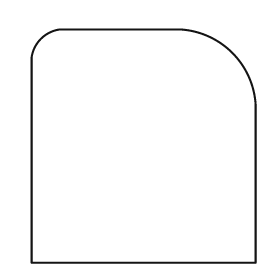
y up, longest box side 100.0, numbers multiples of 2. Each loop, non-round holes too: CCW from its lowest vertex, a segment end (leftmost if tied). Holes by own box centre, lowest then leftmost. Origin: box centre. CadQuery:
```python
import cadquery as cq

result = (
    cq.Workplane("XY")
    .moveTo(-48.0, -50.0)
    .lineTo(48.0, -50.0)
    .lineTo(48.0, 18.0)
    .threePointArc((38.0, 40.0), (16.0, 50.0))
    .lineTo(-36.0, 50.0)
    .threePointArc((-44.0, 46.0), (-48.0, 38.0))
    .close()
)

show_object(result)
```